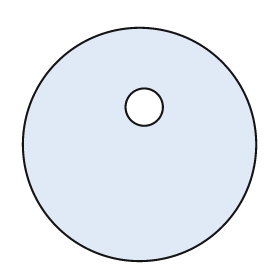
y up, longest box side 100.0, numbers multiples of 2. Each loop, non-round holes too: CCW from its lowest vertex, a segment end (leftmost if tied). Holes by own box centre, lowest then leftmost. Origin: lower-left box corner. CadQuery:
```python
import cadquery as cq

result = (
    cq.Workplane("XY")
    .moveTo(50.0, 50.0)
    .circle(50.0)
    .moveTo(52.0, 66.0)
    .circle(8.0)
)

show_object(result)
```